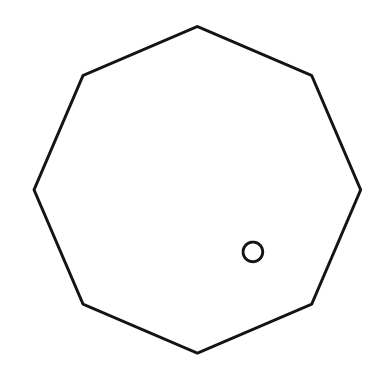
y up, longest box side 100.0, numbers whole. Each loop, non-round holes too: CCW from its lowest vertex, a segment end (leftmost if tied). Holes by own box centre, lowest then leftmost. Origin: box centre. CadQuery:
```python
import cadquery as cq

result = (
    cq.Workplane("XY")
    .moveTo(0.0, -50.0)
    .lineTo(35.0, -35.0)
    .lineTo(50.0, 0.0)
    .lineTo(35.0, 35.0)
    .lineTo(0.0, 50.0)
    .lineTo(-35.0, 35.0)
    .lineTo(-50.0, 0.0)
    .lineTo(-35.0, -35.0)
    .close()
    .moveTo(17.0, -19.0)
    .circle(3.0)
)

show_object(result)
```